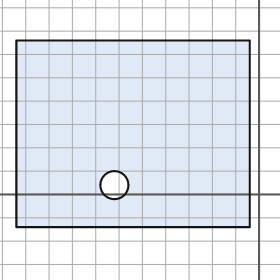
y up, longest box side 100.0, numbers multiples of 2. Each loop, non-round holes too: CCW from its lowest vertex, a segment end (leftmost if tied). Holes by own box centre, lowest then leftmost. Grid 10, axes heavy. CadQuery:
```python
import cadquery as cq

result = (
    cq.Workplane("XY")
    .moveTo(-104.0, -14.0)
    .lineTo(-4.0, -14.0)
    .lineTo(-4.0, 66.0)
    .lineTo(-104.0, 66.0)
    .close()
    .moveTo(-62.0, 4.0)
    .circle(6.0)
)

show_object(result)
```